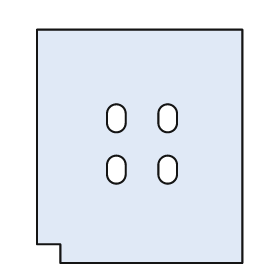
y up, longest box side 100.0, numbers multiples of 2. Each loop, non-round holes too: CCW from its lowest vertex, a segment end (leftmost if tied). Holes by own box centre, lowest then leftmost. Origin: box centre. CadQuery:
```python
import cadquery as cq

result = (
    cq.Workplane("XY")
    .moveTo(-34.0, -50.0)
    .lineTo(44.0, -50.0)
    .lineTo(44.0, 50.0)
    .lineTo(-44.0, 50.0)
    .lineTo(-44.0, -42.0)
    .lineTo(-34.0, -42.0)
    .close()
    .moveTo(-14.0, -12.0)
    .threePointArc((-10.0, -16.0), (-6.0, -12.0))
    .lineTo(-6.0, -8.0)
    .threePointArc((-10.0, -4.0), (-14.0, -8.0))
    .close()
    .moveTo(8.0, -12.0)
    .threePointArc((12.0, -16.0), (16.0, -12.0))
    .lineTo(16.0, -8.0)
    .threePointArc((12.0, -4.0), (8.0, -8.0))
    .close()
    .moveTo(-14.0, 10.0)
    .threePointArc((-10.0, 6.0), (-6.0, 10.0))
    .lineTo(-6.0, 14.0)
    .threePointArc((-10.0, 18.0), (-14.0, 14.0))
    .close()
    .moveTo(8.0, 10.0)
    .threePointArc((12.0, 6.0), (16.0, 10.0))
    .lineTo(16.0, 14.0)
    .threePointArc((12.0, 18.0), (8.0, 14.0))
    .close()
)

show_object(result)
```